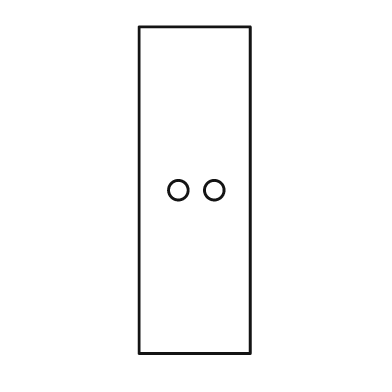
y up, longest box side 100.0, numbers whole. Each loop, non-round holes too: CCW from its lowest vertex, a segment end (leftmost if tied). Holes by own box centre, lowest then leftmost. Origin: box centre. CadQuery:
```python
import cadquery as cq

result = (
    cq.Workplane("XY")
    .moveTo(-17.0, -50.0)
    .lineTo(17.0, -50.0)
    .lineTo(17.0, 50.0)
    .lineTo(-17.0, 50.0)
    .close()
    .moveTo(-5.0, 0.0)
    .circle(3.0)
    .moveTo(6.0, 0.0)
    .circle(3.0)
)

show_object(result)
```